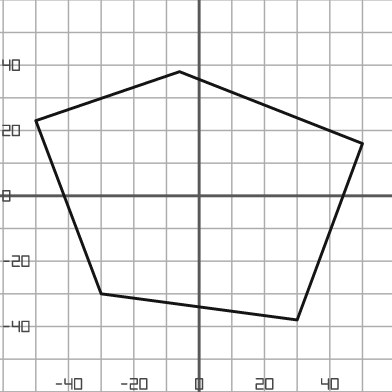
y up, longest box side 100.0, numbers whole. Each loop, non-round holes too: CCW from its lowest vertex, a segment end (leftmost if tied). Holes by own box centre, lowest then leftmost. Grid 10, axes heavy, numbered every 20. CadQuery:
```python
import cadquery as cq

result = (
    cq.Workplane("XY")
    .moveTo(30.0, -38.0)
    .lineTo(50.0, 16.0)
    .lineTo(-6.0, 38.0)
    .lineTo(-50.0, 23.0)
    .lineTo(-30.0, -30.0)
    .close()
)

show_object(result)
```